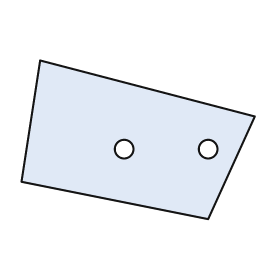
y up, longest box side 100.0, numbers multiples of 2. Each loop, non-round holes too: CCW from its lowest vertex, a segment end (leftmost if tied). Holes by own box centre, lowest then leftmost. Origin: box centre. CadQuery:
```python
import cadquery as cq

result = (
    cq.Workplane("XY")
    .moveTo(30.0, -34.0)
    .lineTo(50.0, 10.0)
    .lineTo(-42.0, 34.0)
    .lineTo(-50.0, -18.0)
    .close()
    .moveTo(-6.0, -4.0)
    .circle(4.0)
    .moveTo(30.0, -4.0)
    .circle(4.0)
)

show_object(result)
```